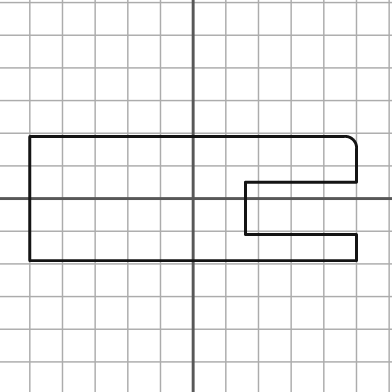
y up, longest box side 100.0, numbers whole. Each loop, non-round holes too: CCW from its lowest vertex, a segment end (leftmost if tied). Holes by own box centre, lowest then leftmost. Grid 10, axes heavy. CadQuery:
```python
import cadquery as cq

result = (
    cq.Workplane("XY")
    .moveTo(-50.0, -19.0)
    .lineTo(50.0, -19.0)
    .lineTo(50.0, -11.0)
    .lineTo(16.0, -11.0)
    .lineTo(16.0, 5.0)
    .lineTo(50.0, 5.0)
    .lineTo(50.0, 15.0)
    .threePointArc((49.0, 18.0), (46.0, 19.0))
    .lineTo(-50.0, 19.0)
    .close()
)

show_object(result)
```